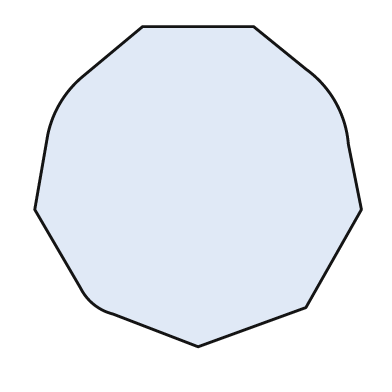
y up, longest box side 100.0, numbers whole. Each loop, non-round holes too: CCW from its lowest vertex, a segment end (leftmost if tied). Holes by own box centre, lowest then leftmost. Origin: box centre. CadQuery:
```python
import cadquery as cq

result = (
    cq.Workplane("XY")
    .moveTo(0.0, -49.0)
    .lineTo(33.0, -37.0)
    .lineTo(50.0, -7.0)
    .lineTo(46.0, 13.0)
    .threePointArc((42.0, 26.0), (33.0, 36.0))
    .lineTo(17.0, 49.0)
    .lineTo(-17.0, 49.0)
    .lineTo(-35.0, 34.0)
    .threePointArc((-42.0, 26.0), (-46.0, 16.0))
    .lineTo(-50.0, -7.0)
    .lineTo(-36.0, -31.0)
    .threePointArc((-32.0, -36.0), (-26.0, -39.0))
    .close()
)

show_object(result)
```